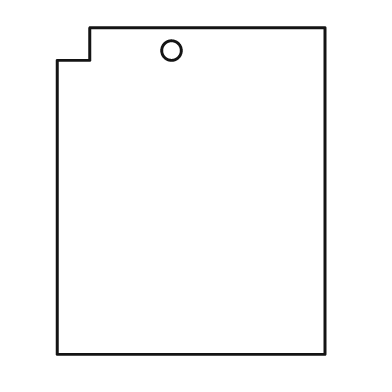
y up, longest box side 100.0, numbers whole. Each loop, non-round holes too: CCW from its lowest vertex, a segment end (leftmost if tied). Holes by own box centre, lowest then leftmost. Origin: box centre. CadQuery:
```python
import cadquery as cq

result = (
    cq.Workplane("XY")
    .moveTo(-41.0, -50.0)
    .lineTo(41.0, -50.0)
    .lineTo(41.0, 50.0)
    .lineTo(-31.0, 50.0)
    .lineTo(-31.0, 40.0)
    .lineTo(-41.0, 40.0)
    .close()
    .moveTo(-6.0, 43.0)
    .circle(3.0)
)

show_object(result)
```